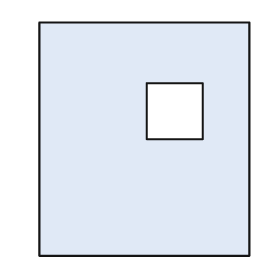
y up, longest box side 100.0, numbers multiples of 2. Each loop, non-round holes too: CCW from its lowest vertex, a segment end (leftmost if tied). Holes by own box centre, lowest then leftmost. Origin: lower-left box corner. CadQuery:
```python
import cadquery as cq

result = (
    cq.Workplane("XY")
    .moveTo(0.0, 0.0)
    .lineTo(90.0, 0.0)
    .lineTo(90.0, 100.0)
    .lineTo(0.0, 100.0)
    .close()
    .moveTo(46.0, 50.0)
    .lineTo(70.0, 50.0)
    .lineTo(70.0, 74.0)
    .lineTo(46.0, 74.0)
    .close()
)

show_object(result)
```